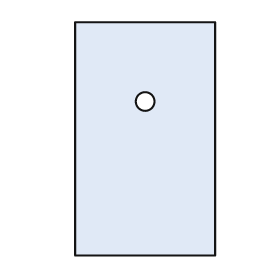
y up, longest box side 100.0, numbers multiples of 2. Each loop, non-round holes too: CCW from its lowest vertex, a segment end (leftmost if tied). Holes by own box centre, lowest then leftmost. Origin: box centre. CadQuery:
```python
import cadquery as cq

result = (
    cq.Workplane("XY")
    .moveTo(-30.0, -50.0)
    .lineTo(30.0, -50.0)
    .lineTo(30.0, 50.0)
    .lineTo(-30.0, 50.0)
    .close()
    .moveTo(0.0, 16.0)
    .circle(4.0)
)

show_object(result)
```